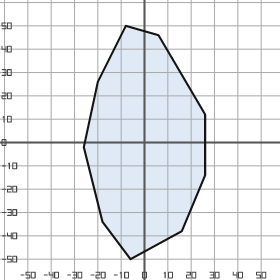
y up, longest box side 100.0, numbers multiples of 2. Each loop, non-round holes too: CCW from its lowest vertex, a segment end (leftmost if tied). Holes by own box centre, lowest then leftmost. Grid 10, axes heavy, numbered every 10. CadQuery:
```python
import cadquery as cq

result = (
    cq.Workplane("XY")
    .moveTo(-6.0, -50.0)
    .lineTo(16.0, -38.0)
    .lineTo(26.0, -14.0)
    .lineTo(26.0, 12.0)
    .lineTo(6.0, 46.0)
    .lineTo(-8.0, 50.0)
    .lineTo(-20.0, 26.0)
    .lineTo(-26.0, -2.0)
    .lineTo(-18.0, -34.0)
    .close()
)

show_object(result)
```